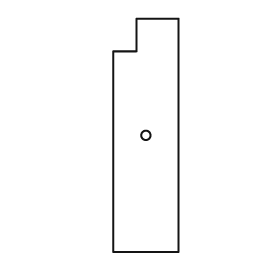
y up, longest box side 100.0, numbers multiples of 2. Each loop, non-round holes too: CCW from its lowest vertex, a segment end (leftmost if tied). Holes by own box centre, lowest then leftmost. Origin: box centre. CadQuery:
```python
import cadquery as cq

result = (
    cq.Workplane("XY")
    .moveTo(-14.0, -50.0)
    .lineTo(14.0, -50.0)
    .lineTo(14.0, 50.0)
    .lineTo(-4.0, 50.0)
    .lineTo(-4.0, 36.0)
    .lineTo(-14.0, 36.0)
    .close()
    .moveTo(0.0, 0.0)
    .circle(2.0)
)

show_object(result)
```